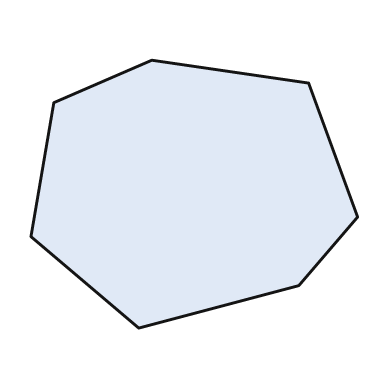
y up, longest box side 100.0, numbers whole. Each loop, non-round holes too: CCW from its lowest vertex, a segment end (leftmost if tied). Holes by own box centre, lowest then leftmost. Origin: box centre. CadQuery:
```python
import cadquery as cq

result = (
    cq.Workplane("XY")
    .moveTo(-17.0, -41.0)
    .lineTo(32.0, -28.0)
    .lineTo(50.0, -7.0)
    .lineTo(35.0, 34.0)
    .lineTo(-13.0, 41.0)
    .lineTo(-43.0, 28.0)
    .lineTo(-50.0, -13.0)
    .close()
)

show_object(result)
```